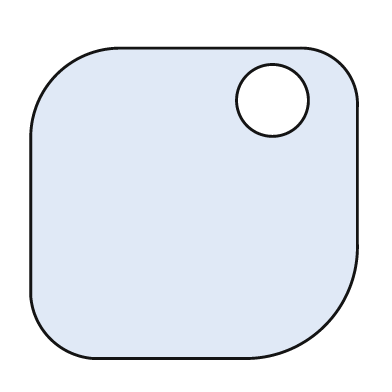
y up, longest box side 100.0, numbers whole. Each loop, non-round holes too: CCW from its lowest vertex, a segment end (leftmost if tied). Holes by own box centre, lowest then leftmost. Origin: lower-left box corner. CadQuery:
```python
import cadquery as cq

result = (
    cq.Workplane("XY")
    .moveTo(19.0, 0.0)
    .lineTo(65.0, 0.0)
    .threePointArc((90.0, 10.0), (100.0, 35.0))
    .lineTo(100.0, 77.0)
    .threePointArc((95.0, 90.0), (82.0, 95.0))
    .lineTo(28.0, 95.0)
    .threePointArc((8.0, 87.0), (0.0, 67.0))
    .lineTo(0.0, 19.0)
    .threePointArc((6.0, 6.0), (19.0, 0.0))
    .close()
    .moveTo(74.0, 79.0)
    .circle(11.0)
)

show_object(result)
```